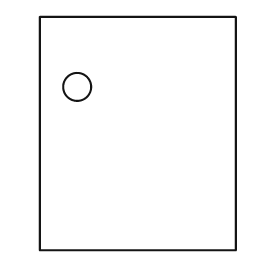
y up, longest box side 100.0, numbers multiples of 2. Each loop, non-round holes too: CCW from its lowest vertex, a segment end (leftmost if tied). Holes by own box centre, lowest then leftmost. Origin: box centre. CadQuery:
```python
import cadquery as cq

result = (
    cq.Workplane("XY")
    .moveTo(-42.0, -50.0)
    .lineTo(42.0, -50.0)
    .lineTo(42.0, 50.0)
    .lineTo(-42.0, 50.0)
    .close()
    .moveTo(-26.0, 20.0)
    .circle(6.0)
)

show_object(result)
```